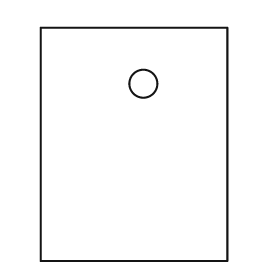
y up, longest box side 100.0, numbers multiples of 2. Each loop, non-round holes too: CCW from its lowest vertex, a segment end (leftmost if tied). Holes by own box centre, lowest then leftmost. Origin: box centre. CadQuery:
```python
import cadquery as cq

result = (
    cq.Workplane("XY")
    .moveTo(-40.0, -50.0)
    .lineTo(40.0, -50.0)
    .lineTo(40.0, 50.0)
    .lineTo(-40.0, 50.0)
    .close()
    .moveTo(4.0, 26.0)
    .circle(6.0)
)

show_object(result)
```